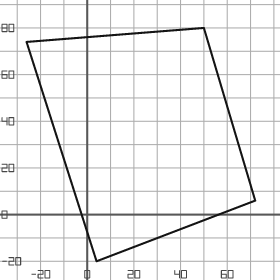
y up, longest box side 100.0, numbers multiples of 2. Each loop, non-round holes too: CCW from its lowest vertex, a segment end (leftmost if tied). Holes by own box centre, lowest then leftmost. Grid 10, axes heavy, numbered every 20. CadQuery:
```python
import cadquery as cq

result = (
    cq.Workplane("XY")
    .moveTo(4.0, -20.0)
    .lineTo(72.0, 6.0)
    .lineTo(50.0, 80.0)
    .lineTo(-26.0, 74.0)
    .close()
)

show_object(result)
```